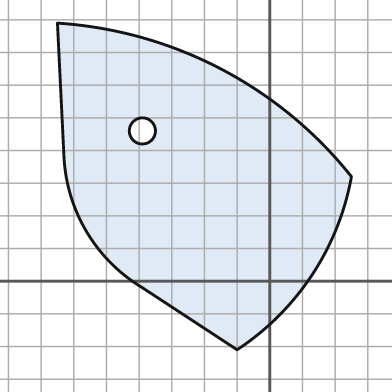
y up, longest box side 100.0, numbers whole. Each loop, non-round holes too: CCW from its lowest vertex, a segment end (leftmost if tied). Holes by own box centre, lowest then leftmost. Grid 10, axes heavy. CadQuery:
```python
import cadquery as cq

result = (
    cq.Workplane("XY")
    .moveTo(-10.0, -21.0)
    .threePointArc((13.0, 2.0), (25.0, 32.0))
    .threePointArc((-15.0, 65.0), (-65.0, 79.0))
    .lineTo(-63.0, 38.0)
    .threePointArc((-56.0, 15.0), (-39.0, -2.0))
    .close()
    .moveTo(-39.0, 46.0)
    .circle(4.0)
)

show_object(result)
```